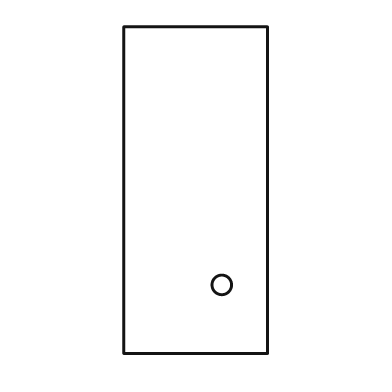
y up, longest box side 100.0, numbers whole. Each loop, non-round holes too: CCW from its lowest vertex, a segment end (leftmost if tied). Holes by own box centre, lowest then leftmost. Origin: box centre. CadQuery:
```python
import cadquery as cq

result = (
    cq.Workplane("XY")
    .moveTo(-22.0, -50.0)
    .lineTo(22.0, -50.0)
    .lineTo(22.0, 50.0)
    .lineTo(-22.0, 50.0)
    .close()
    .moveTo(8.0, -29.0)
    .circle(3.0)
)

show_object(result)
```